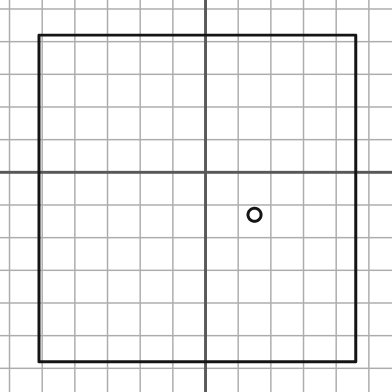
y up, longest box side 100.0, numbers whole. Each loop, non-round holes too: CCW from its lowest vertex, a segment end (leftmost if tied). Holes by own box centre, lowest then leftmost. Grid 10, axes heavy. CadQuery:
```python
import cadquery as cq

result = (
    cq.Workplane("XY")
    .moveTo(-51.0, -58.0)
    .lineTo(46.0, -58.0)
    .lineTo(46.0, 42.0)
    .lineTo(-51.0, 42.0)
    .close()
    .moveTo(15.0, -13.0)
    .circle(2.0)
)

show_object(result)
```